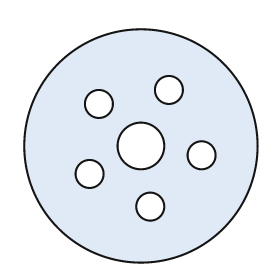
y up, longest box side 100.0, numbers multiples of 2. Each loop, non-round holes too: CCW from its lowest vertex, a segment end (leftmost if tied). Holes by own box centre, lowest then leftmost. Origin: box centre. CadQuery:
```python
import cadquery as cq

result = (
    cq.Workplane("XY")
    .moveTo(0.0, 0.0)
    .circle(50.0)
    .moveTo(4.0, -26.0)
    .circle(6.0)
    .moveTo(-22.0, -12.0)
    .circle(6.0)
    .moveTo(26.0, -4.0)
    .circle(6.0)
    .moveTo(0.0, 0.0)
    .circle(10.0)
    .moveTo(-18.0, 18.0)
    .circle(6.0)
    .moveTo(12.0, 24.0)
    .circle(6.0)
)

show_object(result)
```